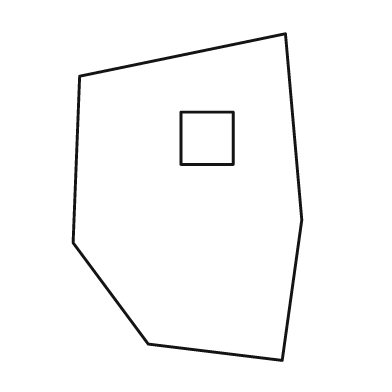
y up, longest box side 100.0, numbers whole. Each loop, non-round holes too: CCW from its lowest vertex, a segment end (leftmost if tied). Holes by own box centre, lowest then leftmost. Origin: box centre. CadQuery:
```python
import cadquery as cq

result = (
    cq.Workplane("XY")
    .moveTo(29.0, -50.0)
    .lineTo(35.0, -7.0)
    .lineTo(30.0, 50.0)
    .lineTo(-33.0, 37.0)
    .lineTo(-35.0, -14.0)
    .lineTo(-12.0, -45.0)
    .close()
    .moveTo(-2.0, 10.0)
    .lineTo(14.0, 10.0)
    .lineTo(14.0, 26.0)
    .lineTo(-2.0, 26.0)
    .close()
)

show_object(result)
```